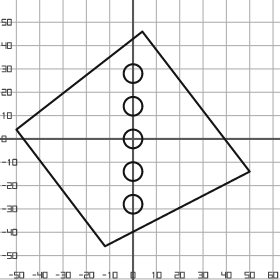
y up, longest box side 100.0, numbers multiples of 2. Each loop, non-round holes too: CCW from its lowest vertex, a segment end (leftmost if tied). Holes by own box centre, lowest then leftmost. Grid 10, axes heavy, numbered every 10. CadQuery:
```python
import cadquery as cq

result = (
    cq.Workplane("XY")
    .moveTo(-12.0, -46.0)
    .lineTo(50.0, -14.0)
    .lineTo(4.0, 46.0)
    .lineTo(-50.0, 4.0)
    .close()
    .moveTo(0.0, -28.0)
    .circle(4.0)
    .moveTo(0.0, -14.0)
    .circle(4.0)
    .moveTo(0.0, 0.0)
    .circle(4.0)
    .moveTo(0.0, 14.0)
    .circle(4.0)
    .moveTo(0.0, 28.0)
    .circle(4.0)
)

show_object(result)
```